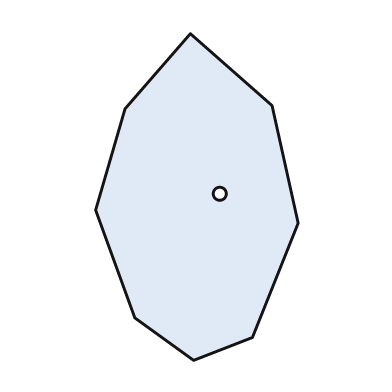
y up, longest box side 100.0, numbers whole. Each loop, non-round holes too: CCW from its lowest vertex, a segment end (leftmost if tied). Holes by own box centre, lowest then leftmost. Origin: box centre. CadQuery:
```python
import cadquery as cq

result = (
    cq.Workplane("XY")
    .moveTo(-1.0, -50.0)
    .lineTo(17.0, -43.0)
    .lineTo(31.0, -8.0)
    .lineTo(23.0, 28.0)
    .lineTo(-2.0, 50.0)
    .lineTo(-22.0, 27.0)
    .lineTo(-31.0, -4.0)
    .lineTo(-19.0, -37.0)
    .close()
    .moveTo(7.0, 1.0)
    .circle(2.0)
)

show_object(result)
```